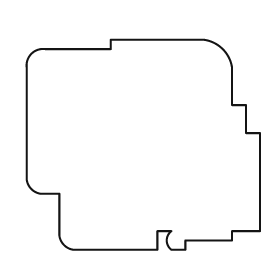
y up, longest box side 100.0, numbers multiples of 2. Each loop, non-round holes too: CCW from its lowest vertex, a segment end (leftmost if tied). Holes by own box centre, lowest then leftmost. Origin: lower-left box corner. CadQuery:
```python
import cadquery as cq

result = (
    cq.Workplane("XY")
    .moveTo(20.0, 0.0)
    .lineTo(56.0, 0.0)
    .lineTo(56.0, 8.0)
    .lineTo(62.0, 8.0)
    .threePointArc((60.0, 4.0), (62.0, 0.0))
    .lineTo(68.0, 0.0)
    .lineTo(68.0, 4.0)
    .lineTo(88.0, 4.0)
    .lineTo(88.0, 8.0)
    .lineTo(100.0, 8.0)
    .lineTo(100.0, 50.0)
    .lineTo(94.0, 50.0)
    .lineTo(94.0, 62.0)
    .lineTo(88.0, 62.0)
    .lineTo(88.0, 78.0)
    .threePointArc((84.0, 86.0), (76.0, 90.0))
    .lineTo(36.0, 90.0)
    .lineTo(36.0, 86.0)
    .lineTo(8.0, 86.0)
    .threePointArc((2.0, 84.0), (0.0, 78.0))
    .lineTo(0.0, 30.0)
    .threePointArc((2.0, 26.0), (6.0, 24.0))
    .lineTo(14.0, 24.0)
    .lineTo(14.0, 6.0)
    .threePointArc((16.0, 2.0), (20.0, 0.0))
    .close()
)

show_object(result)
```